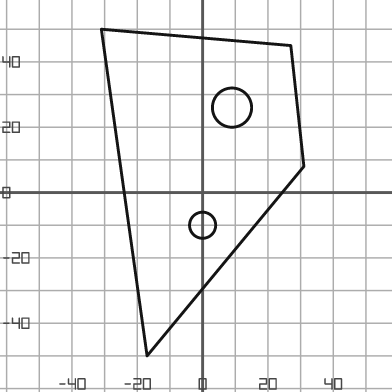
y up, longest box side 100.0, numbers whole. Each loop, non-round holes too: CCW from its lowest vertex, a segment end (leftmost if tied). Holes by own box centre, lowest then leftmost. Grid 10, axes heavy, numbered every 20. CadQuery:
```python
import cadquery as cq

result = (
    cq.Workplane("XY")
    .moveTo(-17.0, -50.0)
    .lineTo(31.0, 8.0)
    .lineTo(27.0, 45.0)
    .lineTo(-31.0, 50.0)
    .close()
    .moveTo(0.0, -10.0)
    .circle(4.0)
    .moveTo(9.0, 26.0)
    .circle(6.0)
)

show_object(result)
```